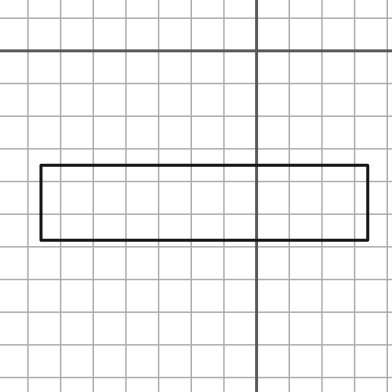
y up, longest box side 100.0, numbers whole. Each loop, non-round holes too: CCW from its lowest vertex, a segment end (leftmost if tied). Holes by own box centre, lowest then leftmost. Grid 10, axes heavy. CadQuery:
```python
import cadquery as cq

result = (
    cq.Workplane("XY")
    .moveTo(-66.0, -58.0)
    .lineTo(34.0, -58.0)
    .lineTo(34.0, -35.0)
    .lineTo(-66.0, -35.0)
    .close()
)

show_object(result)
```